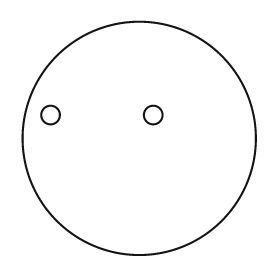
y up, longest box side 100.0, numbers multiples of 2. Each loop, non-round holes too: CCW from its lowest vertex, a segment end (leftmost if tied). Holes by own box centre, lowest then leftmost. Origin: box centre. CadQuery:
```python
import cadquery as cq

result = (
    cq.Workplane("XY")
    .moveTo(0.0, 0.0)
    .circle(50.0)
    .moveTo(-38.0, 10.0)
    .circle(4.0)
    .moveTo(6.0, 10.0)
    .circle(4.0)
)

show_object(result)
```